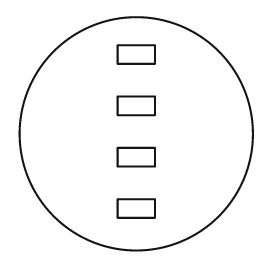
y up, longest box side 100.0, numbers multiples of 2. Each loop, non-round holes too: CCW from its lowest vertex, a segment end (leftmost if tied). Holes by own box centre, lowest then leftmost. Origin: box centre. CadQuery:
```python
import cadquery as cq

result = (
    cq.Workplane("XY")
    .moveTo(0.0, 0.0)
    .circle(50.0)
    .moveTo(-8.0, -36.0)
    .lineTo(8.0, -36.0)
    .lineTo(8.0, -28.0)
    .lineTo(-8.0, -28.0)
    .close()
    .moveTo(-8.0, -14.0)
    .lineTo(8.0, -14.0)
    .lineTo(8.0, -6.0)
    .lineTo(-8.0, -6.0)
    .close()
    .moveTo(-8.0, 8.0)
    .lineTo(8.0, 8.0)
    .lineTo(8.0, 16.0)
    .lineTo(-8.0, 16.0)
    .close()
    .moveTo(-8.0, 30.0)
    .lineTo(8.0, 30.0)
    .lineTo(8.0, 38.0)
    .lineTo(-8.0, 38.0)
    .close()
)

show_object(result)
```